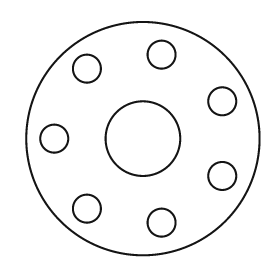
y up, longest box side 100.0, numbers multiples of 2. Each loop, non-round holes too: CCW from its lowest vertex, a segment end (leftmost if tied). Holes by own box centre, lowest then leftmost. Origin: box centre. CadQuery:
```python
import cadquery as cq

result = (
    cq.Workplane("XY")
    .moveTo(0.0, 0.0)
    .circle(50.0)
    .moveTo(8.0, -36.0)
    .circle(6.0)
    .moveTo(-24.0, -30.0)
    .circle(6.0)
    .moveTo(34.0, -16.0)
    .circle(6.0)
    .moveTo(-38.0, 0.0)
    .circle(6.0)
    .moveTo(0.0, 0.0)
    .circle(16.0)
    .moveTo(34.0, 16.0)
    .circle(6.0)
    .moveTo(-24.0, 30.0)
    .circle(6.0)
    .moveTo(8.0, 36.0)
    .circle(6.0)
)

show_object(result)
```